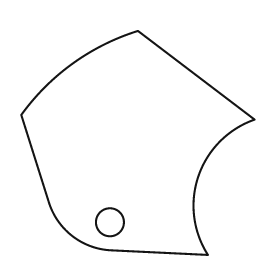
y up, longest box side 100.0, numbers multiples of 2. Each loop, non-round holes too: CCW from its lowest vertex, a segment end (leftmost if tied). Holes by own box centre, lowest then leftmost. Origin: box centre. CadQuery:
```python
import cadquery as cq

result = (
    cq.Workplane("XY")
    .moveTo(30.0, -48.0)
    .threePointArc((26.0, -14.0), (50.0, 10.0))
    .lineTo(0.0, 48.0)
    .threePointArc((-28.0, 34.0), (-50.0, 12.0))
    .lineTo(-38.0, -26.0)
    .threePointArc((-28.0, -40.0), (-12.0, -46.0))
    .close()
    .moveTo(-12.0, -34.0)
    .circle(6.0)
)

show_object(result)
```